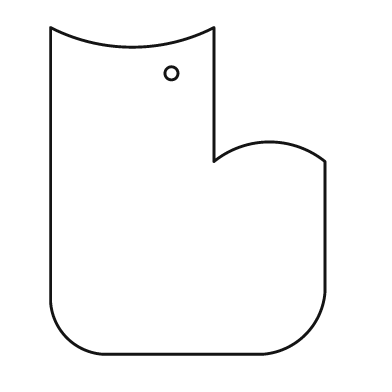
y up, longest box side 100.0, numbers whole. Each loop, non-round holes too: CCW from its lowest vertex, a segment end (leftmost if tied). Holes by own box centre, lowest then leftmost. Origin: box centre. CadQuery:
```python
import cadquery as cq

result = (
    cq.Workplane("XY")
    .moveTo(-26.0, -50.0)
    .lineTo(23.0, -50.0)
    .threePointArc((36.0, -44.0), (42.0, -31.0))
    .lineTo(42.0, 9.0)
    .threePointArc((25.0, 15.0), (8.0, 9.0))
    .lineTo(8.0, 50.0)
    .threePointArc((-17.0, 44.0), (-42.0, 50.0))
    .lineTo(-42.0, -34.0)
    .threePointArc((-37.0, -45.0), (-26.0, -50.0))
    .close()
    .moveTo(-5.0, 36.0)
    .circle(2.0)
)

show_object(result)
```